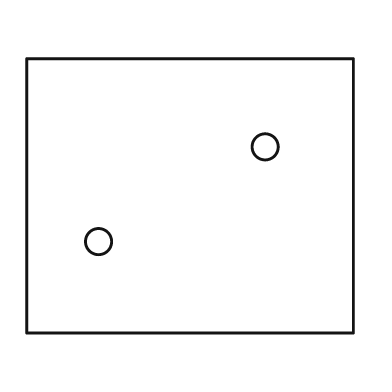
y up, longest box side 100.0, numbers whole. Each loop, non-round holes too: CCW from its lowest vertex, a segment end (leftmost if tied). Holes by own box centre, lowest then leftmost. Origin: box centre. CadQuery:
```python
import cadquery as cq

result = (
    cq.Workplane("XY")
    .moveTo(-50.0, -42.0)
    .lineTo(50.0, -42.0)
    .lineTo(50.0, 42.0)
    .lineTo(-50.0, 42.0)
    .close()
    .moveTo(-28.0, -14.0)
    .circle(4.0)
    .moveTo(23.0, 15.0)
    .circle(4.0)
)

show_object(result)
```